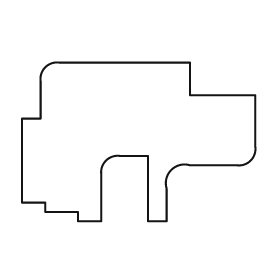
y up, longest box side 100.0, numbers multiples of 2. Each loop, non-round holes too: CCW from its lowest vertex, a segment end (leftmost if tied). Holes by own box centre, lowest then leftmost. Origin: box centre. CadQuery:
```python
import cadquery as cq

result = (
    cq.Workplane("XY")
    .moveTo(-26.0, -34.0)
    .lineTo(-16.0, -34.0)
    .lineTo(-16.0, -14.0)
    .threePointArc((-14.0, -8.0), (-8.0, -6.0))
    .lineTo(4.0, -6.0)
    .lineTo(4.0, -34.0)
    .lineTo(12.0, -34.0)
    .lineTo(12.0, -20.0)
    .threePointArc((14.0, -12.0), (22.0, -10.0))
    .lineTo(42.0, -10.0)
    .threePointArc((48.0, -8.0), (50.0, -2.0))
    .lineTo(50.0, 20.0)
    .lineTo(22.0, 20.0)
    .lineTo(22.0, 34.0)
    .lineTo(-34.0, 34.0)
    .threePointArc((-40.0, 32.0), (-42.0, 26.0))
    .lineTo(-42.0, 10.0)
    .lineTo(-50.0, 10.0)
    .lineTo(-50.0, -26.0)
    .lineTo(-40.0, -26.0)
    .lineTo(-40.0, -30.0)
    .lineTo(-26.0, -30.0)
    .close()
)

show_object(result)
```